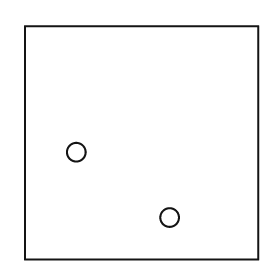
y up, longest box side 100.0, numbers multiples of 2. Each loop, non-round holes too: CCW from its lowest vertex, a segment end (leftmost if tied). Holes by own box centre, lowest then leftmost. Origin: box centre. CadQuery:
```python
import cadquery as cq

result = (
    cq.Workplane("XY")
    .moveTo(-50.0, -50.0)
    .lineTo(50.0, -50.0)
    .lineTo(50.0, 50.0)
    .lineTo(-50.0, 50.0)
    .close()
    .moveTo(12.0, -32.0)
    .circle(4.0)
    .moveTo(-28.0, -4.0)
    .circle(4.0)
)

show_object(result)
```